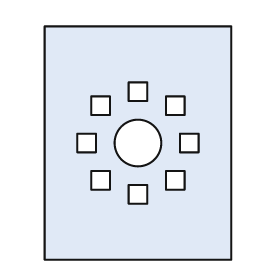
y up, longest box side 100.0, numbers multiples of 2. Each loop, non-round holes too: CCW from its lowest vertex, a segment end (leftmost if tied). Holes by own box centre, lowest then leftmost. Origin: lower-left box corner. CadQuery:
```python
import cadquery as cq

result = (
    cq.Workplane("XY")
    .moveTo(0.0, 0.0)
    .lineTo(80.0, 0.0)
    .lineTo(80.0, 100.0)
    .lineTo(0.0, 100.0)
    .close()
    .moveTo(36.0, 24.0)
    .lineTo(44.0, 24.0)
    .lineTo(44.0, 32.0)
    .lineTo(36.0, 32.0)
    .close()
    .moveTo(20.0, 30.0)
    .lineTo(28.0, 30.0)
    .lineTo(28.0, 38.0)
    .lineTo(20.0, 38.0)
    .close()
    .moveTo(52.0, 30.0)
    .lineTo(60.0, 30.0)
    .lineTo(60.0, 38.0)
    .lineTo(52.0, 38.0)
    .close()
    .moveTo(14.0, 46.0)
    .lineTo(22.0, 46.0)
    .lineTo(22.0, 54.0)
    .lineTo(14.0, 54.0)
    .close()
    .moveTo(40.0, 50.0)
    .circle(10.0)
    .moveTo(58.0, 46.0)
    .lineTo(66.0, 46.0)
    .lineTo(66.0, 54.0)
    .lineTo(58.0, 54.0)
    .close()
    .moveTo(20.0, 62.0)
    .lineTo(28.0, 62.0)
    .lineTo(28.0, 70.0)
    .lineTo(20.0, 70.0)
    .close()
    .moveTo(52.0, 62.0)
    .lineTo(60.0, 62.0)
    .lineTo(60.0, 70.0)
    .lineTo(52.0, 70.0)
    .close()
    .moveTo(36.0, 68.0)
    .lineTo(44.0, 68.0)
    .lineTo(44.0, 76.0)
    .lineTo(36.0, 76.0)
    .close()
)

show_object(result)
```